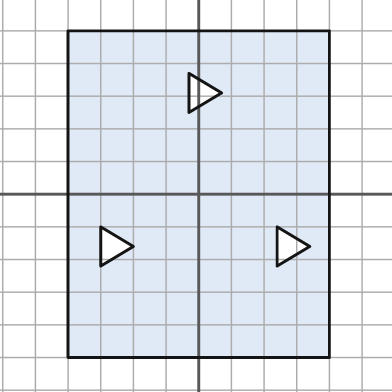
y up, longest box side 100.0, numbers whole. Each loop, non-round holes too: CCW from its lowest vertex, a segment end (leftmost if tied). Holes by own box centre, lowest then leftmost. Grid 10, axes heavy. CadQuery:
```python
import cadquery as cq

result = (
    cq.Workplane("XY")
    .moveTo(-40.0, -50.0)
    .lineTo(40.0, -50.0)
    .lineTo(40.0, 50.0)
    .lineTo(-40.0, 50.0)
    .close()
    .moveTo(-30.0, -22.0)
    .lineTo(-20.0, -16.0)
    .lineTo(-30.0, -10.0)
    .close()
    .moveTo(24.0, -22.0)
    .lineTo(34.0, -16.0)
    .lineTo(24.0, -10.0)
    .close()
    .moveTo(-3.0, 25.0)
    .lineTo(7.0, 31.0)
    .lineTo(-3.0, 37.0)
    .close()
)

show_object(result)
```